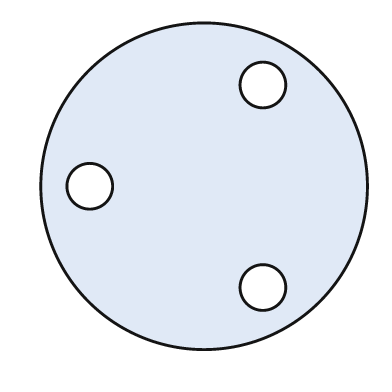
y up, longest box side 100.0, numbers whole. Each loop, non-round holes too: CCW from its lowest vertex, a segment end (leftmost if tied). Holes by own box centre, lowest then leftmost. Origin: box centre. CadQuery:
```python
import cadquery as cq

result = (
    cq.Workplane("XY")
    .moveTo(0.0, 0.0)
    .circle(50.0)
    .moveTo(18.0, -31.0)
    .circle(7.0)
    .moveTo(-35.0, 0.0)
    .circle(7.0)
    .moveTo(18.0, 31.0)
    .circle(7.0)
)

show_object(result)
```